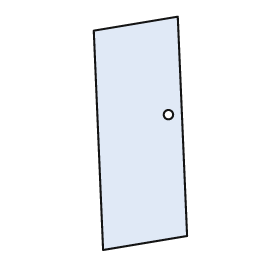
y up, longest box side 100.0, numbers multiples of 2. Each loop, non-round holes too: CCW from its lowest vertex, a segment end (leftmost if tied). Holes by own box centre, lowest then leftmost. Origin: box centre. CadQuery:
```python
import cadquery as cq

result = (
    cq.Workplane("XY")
    .moveTo(-16.0, -50.0)
    .lineTo(20.0, -44.0)
    .lineTo(16.0, 50.0)
    .lineTo(-20.0, 44.0)
    .close()
    .moveTo(12.0, 8.0)
    .circle(2.0)
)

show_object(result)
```